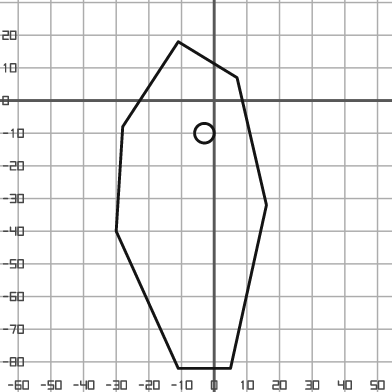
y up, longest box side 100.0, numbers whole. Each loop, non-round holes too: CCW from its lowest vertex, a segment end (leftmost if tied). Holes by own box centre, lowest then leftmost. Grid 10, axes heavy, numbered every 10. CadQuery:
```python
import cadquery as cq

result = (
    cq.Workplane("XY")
    .moveTo(-11.0, -82.0)
    .lineTo(5.0, -82.0)
    .lineTo(16.0, -32.0)
    .lineTo(7.0, 7.0)
    .lineTo(-11.0, 18.0)
    .lineTo(-28.0, -8.0)
    .lineTo(-30.0, -40.0)
    .close()
    .moveTo(-3.0, -10.0)
    .circle(3.0)
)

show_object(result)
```